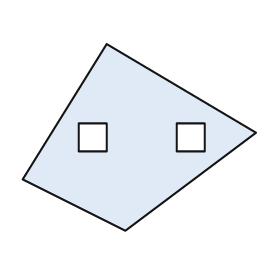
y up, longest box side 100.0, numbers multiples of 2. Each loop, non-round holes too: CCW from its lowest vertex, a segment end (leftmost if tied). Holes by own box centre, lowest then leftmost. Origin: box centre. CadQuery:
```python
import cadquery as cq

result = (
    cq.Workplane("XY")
    .moveTo(-6.0, -40.0)
    .lineTo(50.0, 2.0)
    .lineTo(-14.0, 40.0)
    .lineTo(-50.0, -18.0)
    .close()
    .moveTo(-26.0, -6.0)
    .lineTo(-14.0, -6.0)
    .lineTo(-14.0, 6.0)
    .lineTo(-26.0, 6.0)
    .close()
    .moveTo(16.0, -6.0)
    .lineTo(28.0, -6.0)
    .lineTo(28.0, 6.0)
    .lineTo(16.0, 6.0)
    .close()
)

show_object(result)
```